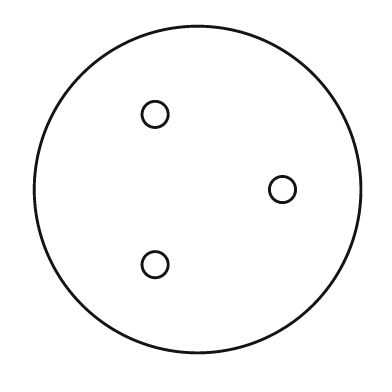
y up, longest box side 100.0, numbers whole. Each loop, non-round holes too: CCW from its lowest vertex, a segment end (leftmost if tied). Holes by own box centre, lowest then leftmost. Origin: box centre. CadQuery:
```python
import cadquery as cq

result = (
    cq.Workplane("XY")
    .moveTo(0.0, 0.0)
    .circle(50.0)
    .moveTo(-13.0, -23.0)
    .circle(4.0)
    .moveTo(26.0, 0.0)
    .circle(4.0)
    .moveTo(-13.0, 23.0)
    .circle(4.0)
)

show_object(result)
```